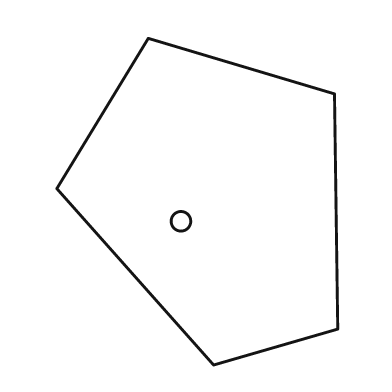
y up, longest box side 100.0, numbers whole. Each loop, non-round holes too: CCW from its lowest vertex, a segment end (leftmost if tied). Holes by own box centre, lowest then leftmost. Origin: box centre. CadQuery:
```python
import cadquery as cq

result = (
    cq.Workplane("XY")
    .moveTo(5.0, -50.0)
    .lineTo(43.0, -39.0)
    .lineTo(42.0, 33.0)
    .lineTo(-15.0, 50.0)
    .lineTo(-43.0, 4.0)
    .close()
    .moveTo(-5.0, -6.0)
    .circle(3.0)
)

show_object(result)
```